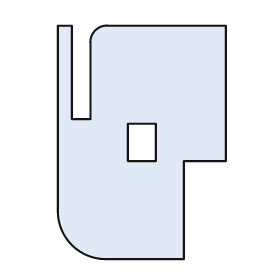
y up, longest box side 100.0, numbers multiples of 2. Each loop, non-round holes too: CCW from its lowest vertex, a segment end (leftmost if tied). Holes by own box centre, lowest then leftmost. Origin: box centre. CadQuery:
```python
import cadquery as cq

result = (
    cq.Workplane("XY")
    .moveTo(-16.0, -50.0)
    .lineTo(18.0, -50.0)
    .lineTo(18.0, -8.0)
    .lineTo(36.0, -8.0)
    .lineTo(36.0, 50.0)
    .lineTo(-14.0, 50.0)
    .threePointArc((-20.0, 48.0), (-22.0, 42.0))
    .lineTo(-22.0, 10.0)
    .lineTo(-30.0, 10.0)
    .lineTo(-30.0, 50.0)
    .lineTo(-36.0, 50.0)
    .lineTo(-36.0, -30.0)
    .threePointArc((-30.0, -44.0), (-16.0, -50.0))
    .close()
    .moveTo(-6.0, -8.0)
    .lineTo(6.0, -8.0)
    .lineTo(6.0, 8.0)
    .lineTo(-6.0, 8.0)
    .close()
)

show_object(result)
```